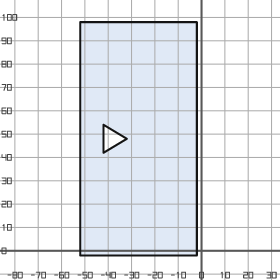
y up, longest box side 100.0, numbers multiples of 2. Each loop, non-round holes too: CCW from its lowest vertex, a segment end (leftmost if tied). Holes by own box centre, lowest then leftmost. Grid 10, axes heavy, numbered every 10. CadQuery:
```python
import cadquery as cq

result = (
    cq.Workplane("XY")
    .moveTo(-52.0, -2.0)
    .lineTo(-2.0, -2.0)
    .lineTo(-2.0, 98.0)
    .lineTo(-52.0, 98.0)
    .close()
    .moveTo(-42.0, 42.0)
    .lineTo(-32.0, 48.0)
    .lineTo(-42.0, 54.0)
    .close()
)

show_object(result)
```